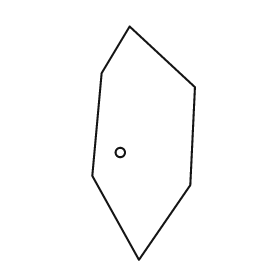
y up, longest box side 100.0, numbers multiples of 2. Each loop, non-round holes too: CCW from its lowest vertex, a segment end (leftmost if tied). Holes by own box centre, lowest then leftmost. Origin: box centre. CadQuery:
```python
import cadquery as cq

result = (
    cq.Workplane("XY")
    .moveTo(-2.0, -50.0)
    .lineTo(20.0, -18.0)
    .lineTo(22.0, 24.0)
    .lineTo(-6.0, 50.0)
    .lineTo(-18.0, 30.0)
    .lineTo(-22.0, -14.0)
    .close()
    .moveTo(-10.0, -4.0)
    .circle(2.0)
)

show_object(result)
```